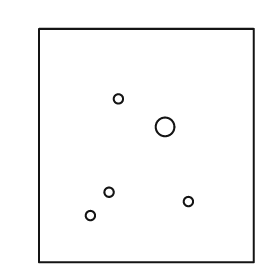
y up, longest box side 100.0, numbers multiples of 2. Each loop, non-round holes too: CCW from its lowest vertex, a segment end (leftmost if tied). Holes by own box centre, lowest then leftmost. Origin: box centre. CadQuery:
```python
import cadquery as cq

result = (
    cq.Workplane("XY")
    .moveTo(-46.0, -50.0)
    .lineTo(46.0, -50.0)
    .lineTo(46.0, 50.0)
    .lineTo(-46.0, 50.0)
    .close()
    .moveTo(-24.0, -30.0)
    .circle(2.0)
    .moveTo(18.0, -24.0)
    .circle(2.0)
    .moveTo(-16.0, -20.0)
    .circle(2.0)
    .moveTo(8.0, 8.0)
    .circle(4.0)
    .moveTo(-12.0, 20.0)
    .circle(2.0)
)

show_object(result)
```